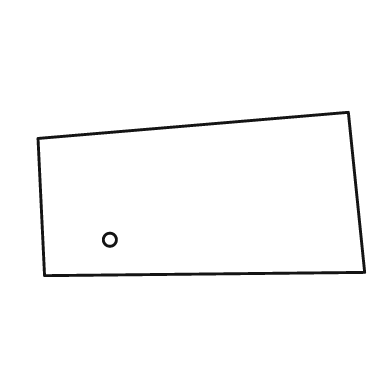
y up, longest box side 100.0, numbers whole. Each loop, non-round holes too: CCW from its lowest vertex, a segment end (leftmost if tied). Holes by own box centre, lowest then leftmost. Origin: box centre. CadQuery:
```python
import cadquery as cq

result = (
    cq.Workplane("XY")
    .moveTo(-48.0, -25.0)
    .lineTo(50.0, -24.0)
    .lineTo(45.0, 25.0)
    .lineTo(-50.0, 17.0)
    .close()
    .moveTo(-28.0, -14.0)
    .circle(2.0)
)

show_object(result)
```